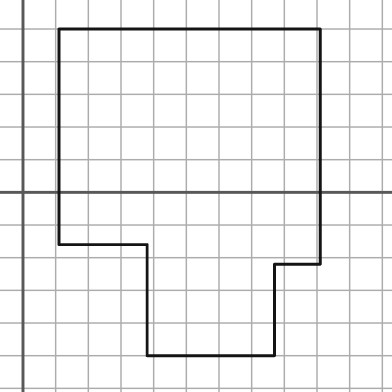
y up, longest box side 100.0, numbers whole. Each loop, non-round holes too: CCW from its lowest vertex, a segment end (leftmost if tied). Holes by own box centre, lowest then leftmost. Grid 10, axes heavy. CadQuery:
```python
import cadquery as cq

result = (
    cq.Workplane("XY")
    .moveTo(38.0, -50.0)
    .lineTo(77.0, -50.0)
    .lineTo(77.0, -22.0)
    .lineTo(91.0, -22.0)
    .lineTo(91.0, 50.0)
    .lineTo(11.0, 50.0)
    .lineTo(11.0, -16.0)
    .lineTo(38.0, -16.0)
    .close()
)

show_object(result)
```